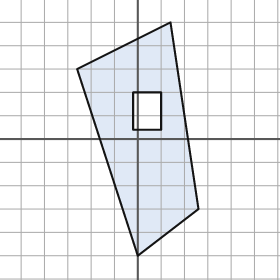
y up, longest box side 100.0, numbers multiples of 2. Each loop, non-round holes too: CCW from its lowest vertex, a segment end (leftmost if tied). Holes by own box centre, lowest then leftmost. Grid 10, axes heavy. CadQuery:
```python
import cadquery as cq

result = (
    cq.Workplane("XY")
    .moveTo(0.0, -50.0)
    .lineTo(26.0, -30.0)
    .lineTo(14.0, 50.0)
    .lineTo(-26.0, 30.0)
    .close()
    .moveTo(-2.0, 4.0)
    .lineTo(10.0, 4.0)
    .lineTo(10.0, 20.0)
    .lineTo(-2.0, 20.0)
    .close()
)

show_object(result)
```